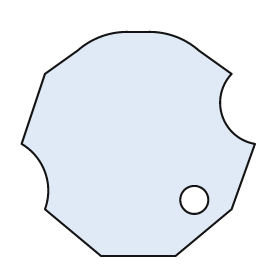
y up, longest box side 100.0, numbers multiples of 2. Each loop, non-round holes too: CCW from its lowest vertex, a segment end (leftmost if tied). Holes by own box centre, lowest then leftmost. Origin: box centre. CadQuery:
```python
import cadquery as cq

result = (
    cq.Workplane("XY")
    .moveTo(-16.0, -48.0)
    .lineTo(16.0, -48.0)
    .lineTo(40.0, -28.0)
    .lineTo(50.0, 0.0)
    .threePointArc((36.0, 12.0), (40.0, 30.0))
    .lineTo(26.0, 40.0)
    .threePointArc((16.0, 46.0), (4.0, 48.0))
    .lineTo(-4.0, 48.0)
    .threePointArc((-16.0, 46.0), (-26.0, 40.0))
    .lineTo(-40.0, 30.0)
    .lineTo(-50.0, 0.0)
    .threePointArc((-40.0, -12.0), (-40.0, -28.0))
    .close()
    .moveTo(24.0, -24.0)
    .circle(6.0)
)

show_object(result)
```